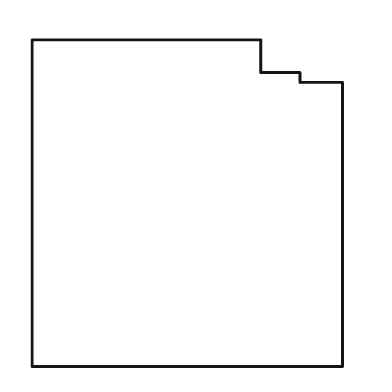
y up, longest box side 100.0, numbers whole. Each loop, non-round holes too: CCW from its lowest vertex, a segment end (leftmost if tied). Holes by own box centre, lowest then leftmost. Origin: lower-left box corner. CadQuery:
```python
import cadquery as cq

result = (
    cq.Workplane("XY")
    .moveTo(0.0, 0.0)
    .lineTo(95.0, 0.0)
    .lineTo(95.0, 87.0)
    .lineTo(82.0, 87.0)
    .lineTo(82.0, 90.0)
    .lineTo(70.0, 90.0)
    .lineTo(70.0, 100.0)
    .lineTo(0.0, 100.0)
    .close()
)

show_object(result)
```